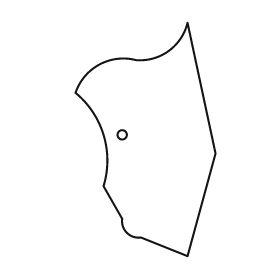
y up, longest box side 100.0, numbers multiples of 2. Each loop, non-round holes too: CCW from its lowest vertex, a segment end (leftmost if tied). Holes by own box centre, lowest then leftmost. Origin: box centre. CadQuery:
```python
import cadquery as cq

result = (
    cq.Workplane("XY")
    .moveTo(18.0, -50.0)
    .lineTo(30.0, -6.0)
    .lineTo(18.0, 50.0)
    .threePointArc((10.0, 38.0), (-4.0, 34.0))
    .threePointArc((-20.0, 32.0), (-30.0, 20.0))
    .threePointArc((-18.0, 2.0), (-18.0, -20.0))
    .lineTo(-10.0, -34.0)
    .threePointArc((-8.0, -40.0), (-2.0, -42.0))
    .close()
    .moveTo(-10.0, 2.0)
    .circle(2.0)
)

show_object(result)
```